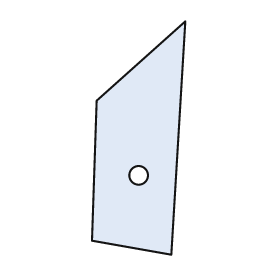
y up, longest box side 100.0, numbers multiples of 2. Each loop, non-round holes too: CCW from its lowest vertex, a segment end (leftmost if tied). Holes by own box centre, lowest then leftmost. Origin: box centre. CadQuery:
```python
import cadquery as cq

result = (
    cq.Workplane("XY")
    .moveTo(14.0, -50.0)
    .lineTo(20.0, 50.0)
    .lineTo(-18.0, 16.0)
    .lineTo(-20.0, -44.0)
    .close()
    .moveTo(0.0, -16.0)
    .circle(4.0)
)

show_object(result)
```